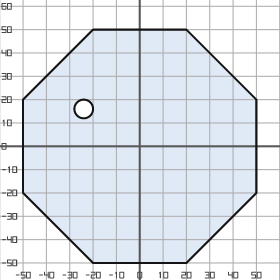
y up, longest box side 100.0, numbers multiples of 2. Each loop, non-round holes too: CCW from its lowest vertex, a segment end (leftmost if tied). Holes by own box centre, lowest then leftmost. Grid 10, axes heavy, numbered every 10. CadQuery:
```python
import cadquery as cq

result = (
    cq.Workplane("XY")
    .moveTo(-20.0, -50.0)
    .lineTo(20.0, -50.0)
    .lineTo(50.0, -20.0)
    .lineTo(50.0, 20.0)
    .lineTo(20.0, 50.0)
    .lineTo(-20.0, 50.0)
    .lineTo(-50.0, 20.0)
    .lineTo(-50.0, -20.0)
    .close()
    .moveTo(-24.0, 16.0)
    .circle(4.0)
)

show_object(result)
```